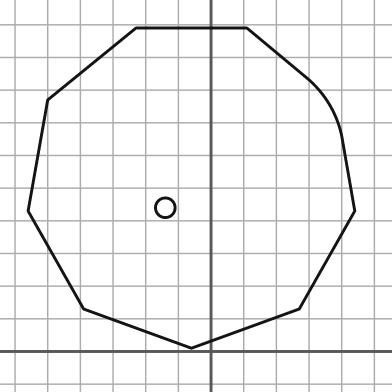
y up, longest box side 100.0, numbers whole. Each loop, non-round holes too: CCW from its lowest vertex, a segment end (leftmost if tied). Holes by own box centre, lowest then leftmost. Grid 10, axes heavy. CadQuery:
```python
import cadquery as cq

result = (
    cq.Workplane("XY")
    .moveTo(-6.0, 1.0)
    .lineTo(27.0, 13.0)
    .lineTo(44.0, 43.0)
    .lineTo(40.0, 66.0)
    .threePointArc((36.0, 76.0), (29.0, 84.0))
    .lineTo(11.0, 99.0)
    .lineTo(-23.0, 99.0)
    .lineTo(-50.0, 77.0)
    .lineTo(-56.0, 43.0)
    .lineTo(-39.0, 13.0)
    .close()
    .moveTo(-14.0, 44.0)
    .circle(3.0)
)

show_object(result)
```